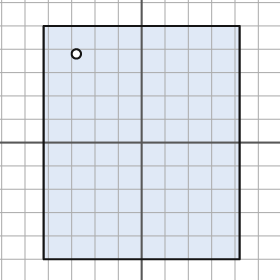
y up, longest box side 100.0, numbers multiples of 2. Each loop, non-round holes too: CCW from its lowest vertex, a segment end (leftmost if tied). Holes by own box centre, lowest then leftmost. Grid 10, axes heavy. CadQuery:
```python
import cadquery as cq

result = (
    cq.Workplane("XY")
    .moveTo(-42.0, -50.0)
    .lineTo(42.0, -50.0)
    .lineTo(42.0, 50.0)
    .lineTo(-42.0, 50.0)
    .close()
    .moveTo(-28.0, 38.0)
    .circle(2.0)
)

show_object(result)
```